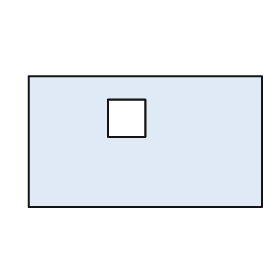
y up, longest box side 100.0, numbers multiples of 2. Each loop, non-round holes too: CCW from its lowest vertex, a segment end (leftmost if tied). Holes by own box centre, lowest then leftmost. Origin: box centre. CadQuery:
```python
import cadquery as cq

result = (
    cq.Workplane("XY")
    .moveTo(-50.0, -28.0)
    .lineTo(50.0, -28.0)
    .lineTo(50.0, 28.0)
    .lineTo(-50.0, 28.0)
    .close()
    .moveTo(-16.0, 2.0)
    .lineTo(0.0, 2.0)
    .lineTo(0.0, 18.0)
    .lineTo(-16.0, 18.0)
    .close()
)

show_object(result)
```